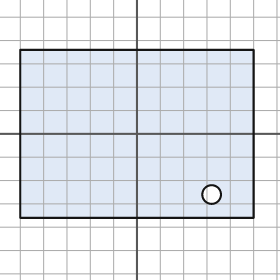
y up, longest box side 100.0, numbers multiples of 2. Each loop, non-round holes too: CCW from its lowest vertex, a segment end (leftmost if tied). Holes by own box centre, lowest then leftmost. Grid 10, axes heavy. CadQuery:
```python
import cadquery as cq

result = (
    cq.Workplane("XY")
    .moveTo(-50.0, -36.0)
    .lineTo(50.0, -36.0)
    .lineTo(50.0, 36.0)
    .lineTo(-50.0, 36.0)
    .close()
    .moveTo(32.0, -26.0)
    .circle(4.0)
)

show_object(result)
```